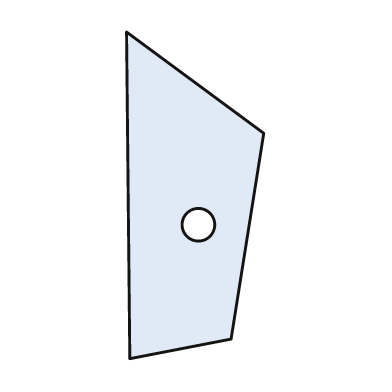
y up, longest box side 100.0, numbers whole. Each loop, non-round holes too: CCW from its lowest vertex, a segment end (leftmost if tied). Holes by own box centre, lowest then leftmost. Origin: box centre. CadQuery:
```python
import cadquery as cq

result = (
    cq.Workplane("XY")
    .moveTo(-20.0, -50.0)
    .lineTo(11.0, -44.0)
    .lineTo(21.0, 19.0)
    .lineTo(-21.0, 50.0)
    .close()
    .moveTo(1.0, -9.0)
    .circle(5.0)
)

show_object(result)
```